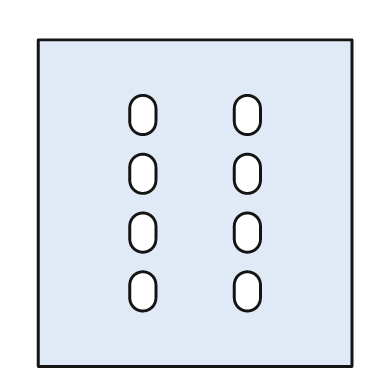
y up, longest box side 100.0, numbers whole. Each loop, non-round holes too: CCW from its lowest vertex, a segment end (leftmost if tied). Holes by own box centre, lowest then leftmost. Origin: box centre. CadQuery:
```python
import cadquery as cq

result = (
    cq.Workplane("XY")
    .moveTo(-48.0, -50.0)
    .lineTo(48.0, -50.0)
    .lineTo(48.0, 50.0)
    .lineTo(-48.0, 50.0)
    .close()
    .moveTo(-20.0, -29.0)
    .threePointArc((-16.0, -33.0), (-12.0, -29.0))
    .lineTo(-12.0, -25.0)
    .threePointArc((-16.0, -21.0), (-20.0, -25.0))
    .close()
    .moveTo(12.0, -29.0)
    .threePointArc((16.0, -33.0), (20.0, -29.0))
    .lineTo(20.0, -25.0)
    .threePointArc((16.0, -21.0), (12.0, -25.0))
    .close()
    .moveTo(-20.0, -11.0)
    .threePointArc((-16.0, -15.0), (-12.0, -11.0))
    .lineTo(-12.0, -7.0)
    .threePointArc((-16.0, -3.0), (-20.0, -7.0))
    .close()
    .moveTo(12.0, -11.0)
    .threePointArc((16.0, -15.0), (20.0, -11.0))
    .lineTo(20.0, -7.0)
    .threePointArc((16.0, -3.0), (12.0, -7.0))
    .close()
    .moveTo(-20.0, 7.0)
    .threePointArc((-16.0, 3.0), (-12.0, 7.0))
    .lineTo(-12.0, 11.0)
    .threePointArc((-16.0, 15.0), (-20.0, 11.0))
    .close()
    .moveTo(12.0, 7.0)
    .threePointArc((16.0, 3.0), (20.0, 7.0))
    .lineTo(20.0, 11.0)
    .threePointArc((16.0, 15.0), (12.0, 11.0))
    .close()
    .moveTo(-20.0, 25.0)
    .threePointArc((-16.0, 21.0), (-12.0, 25.0))
    .lineTo(-12.0, 29.0)
    .threePointArc((-16.0, 33.0), (-20.0, 29.0))
    .close()
    .moveTo(12.0, 25.0)
    .threePointArc((16.0, 21.0), (20.0, 25.0))
    .lineTo(20.0, 29.0)
    .threePointArc((16.0, 33.0), (12.0, 29.0))
    .close()
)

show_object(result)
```